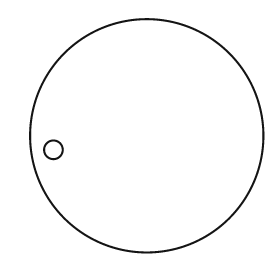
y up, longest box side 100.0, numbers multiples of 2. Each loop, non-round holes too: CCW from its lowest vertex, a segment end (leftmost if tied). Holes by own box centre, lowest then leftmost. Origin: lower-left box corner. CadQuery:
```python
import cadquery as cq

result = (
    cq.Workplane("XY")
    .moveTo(50.0, 50.0)
    .circle(50.0)
    .moveTo(10.0, 44.0)
    .circle(4.0)
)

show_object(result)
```